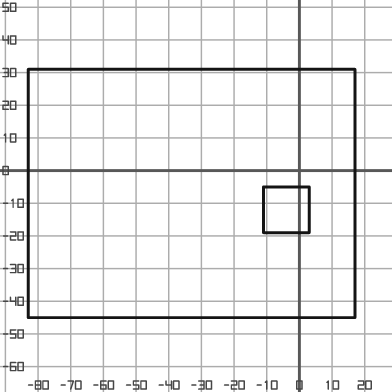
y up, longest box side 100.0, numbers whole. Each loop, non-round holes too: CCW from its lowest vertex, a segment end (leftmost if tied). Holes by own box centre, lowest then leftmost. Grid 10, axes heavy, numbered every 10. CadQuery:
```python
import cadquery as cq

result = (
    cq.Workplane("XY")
    .moveTo(-83.0, -45.0)
    .lineTo(17.0, -45.0)
    .lineTo(17.0, 31.0)
    .lineTo(-83.0, 31.0)
    .close()
    .moveTo(-11.0, -19.0)
    .lineTo(3.0, -19.0)
    .lineTo(3.0, -5.0)
    .lineTo(-11.0, -5.0)
    .close()
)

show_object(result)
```